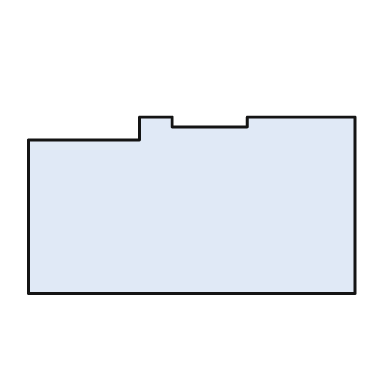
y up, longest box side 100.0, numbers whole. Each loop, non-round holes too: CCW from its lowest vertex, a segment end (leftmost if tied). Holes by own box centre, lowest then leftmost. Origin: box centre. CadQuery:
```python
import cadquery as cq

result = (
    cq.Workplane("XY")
    .moveTo(-50.0, -27.0)
    .lineTo(50.0, -27.0)
    .lineTo(50.0, 27.0)
    .lineTo(17.0, 27.0)
    .lineTo(17.0, 24.0)
    .lineTo(-6.0, 24.0)
    .lineTo(-6.0, 27.0)
    .lineTo(-16.0, 27.0)
    .lineTo(-16.0, 20.0)
    .lineTo(-50.0, 20.0)
    .close()
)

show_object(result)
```